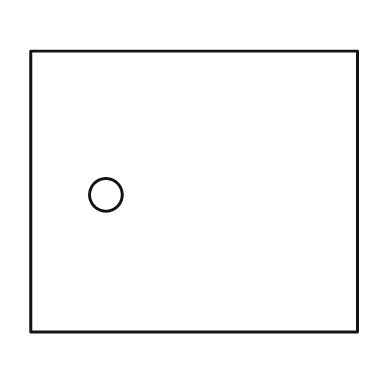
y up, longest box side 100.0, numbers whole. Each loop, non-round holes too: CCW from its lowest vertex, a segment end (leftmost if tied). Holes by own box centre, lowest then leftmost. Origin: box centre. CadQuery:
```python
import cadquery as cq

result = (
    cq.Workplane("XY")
    .moveTo(-50.0, -43.0)
    .lineTo(50.0, -43.0)
    .lineTo(50.0, 43.0)
    .lineTo(-50.0, 43.0)
    .close()
    .moveTo(-27.0, -1.0)
    .circle(5.0)
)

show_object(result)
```